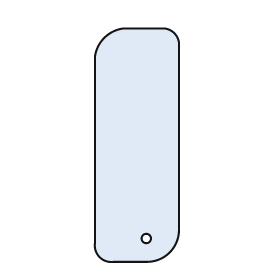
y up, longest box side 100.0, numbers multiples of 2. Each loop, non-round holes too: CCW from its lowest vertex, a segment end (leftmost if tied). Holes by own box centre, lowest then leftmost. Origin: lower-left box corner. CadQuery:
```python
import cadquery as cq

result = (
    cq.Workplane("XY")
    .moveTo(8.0, 0.0)
    .lineTo(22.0, 0.0)
    .threePointArc((32.0, 4.0), (36.0, 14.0))
    .lineTo(36.0, 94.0)
    .threePointArc((34.0, 98.0), (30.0, 100.0))
    .lineTo(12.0, 100.0)
    .threePointArc((4.0, 96.0), (0.0, 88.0))
    .lineTo(0.0, 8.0)
    .threePointArc((2.0, 2.0), (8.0, 0.0))
    .close()
    .moveTo(22.0, 10.0)
    .circle(2.0)
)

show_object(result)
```